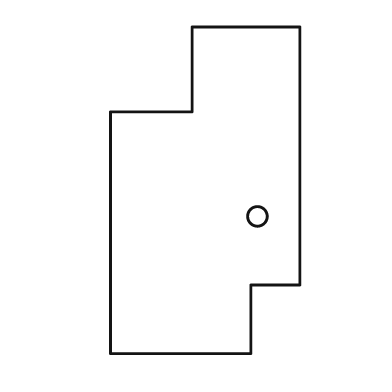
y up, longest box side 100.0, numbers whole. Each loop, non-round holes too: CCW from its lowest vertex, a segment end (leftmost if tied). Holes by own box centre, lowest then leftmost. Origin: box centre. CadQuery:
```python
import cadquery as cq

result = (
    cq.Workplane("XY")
    .moveTo(-29.0, -50.0)
    .lineTo(14.0, -50.0)
    .lineTo(14.0, -29.0)
    .lineTo(29.0, -29.0)
    .lineTo(29.0, 50.0)
    .lineTo(-4.0, 50.0)
    .lineTo(-4.0, 24.0)
    .lineTo(-29.0, 24.0)
    .close()
    .moveTo(16.0, -8.0)
    .circle(3.0)
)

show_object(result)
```